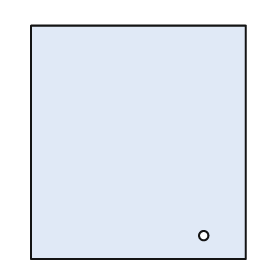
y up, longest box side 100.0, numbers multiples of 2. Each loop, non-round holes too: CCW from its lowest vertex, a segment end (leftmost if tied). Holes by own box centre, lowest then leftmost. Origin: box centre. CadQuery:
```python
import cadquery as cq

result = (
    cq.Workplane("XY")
    .moveTo(-46.0, -50.0)
    .lineTo(46.0, -50.0)
    .lineTo(46.0, 50.0)
    .lineTo(-46.0, 50.0)
    .close()
    .moveTo(28.0, -40.0)
    .circle(2.0)
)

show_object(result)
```